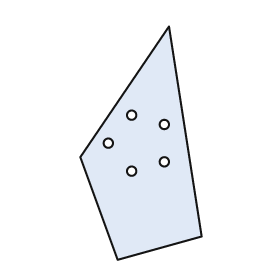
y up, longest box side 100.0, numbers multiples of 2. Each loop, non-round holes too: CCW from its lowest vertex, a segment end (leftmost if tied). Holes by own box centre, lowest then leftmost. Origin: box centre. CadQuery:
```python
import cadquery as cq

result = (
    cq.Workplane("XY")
    .moveTo(-10.0, -50.0)
    .lineTo(26.0, -40.0)
    .lineTo(12.0, 50.0)
    .lineTo(-26.0, -6.0)
    .close()
    .moveTo(-4.0, -12.0)
    .circle(2.0)
    .moveTo(10.0, -8.0)
    .circle(2.0)
    .moveTo(-14.0, 0.0)
    .circle(2.0)
    .moveTo(10.0, 8.0)
    .circle(2.0)
    .moveTo(-4.0, 12.0)
    .circle(2.0)
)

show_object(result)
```